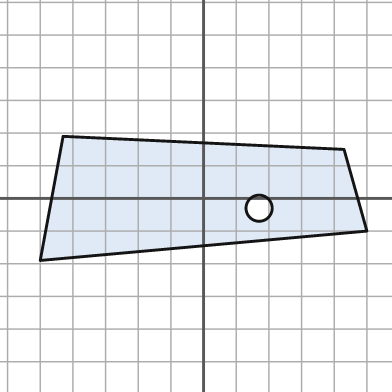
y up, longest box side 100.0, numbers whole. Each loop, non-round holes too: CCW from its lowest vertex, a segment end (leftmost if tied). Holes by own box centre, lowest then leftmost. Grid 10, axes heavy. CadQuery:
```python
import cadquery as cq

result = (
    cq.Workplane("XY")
    .moveTo(-50.0, -19.0)
    .lineTo(50.0, -10.0)
    .lineTo(43.0, 15.0)
    .lineTo(-43.0, 19.0)
    .close()
    .moveTo(17.0, -3.0)
    .circle(4.0)
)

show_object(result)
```